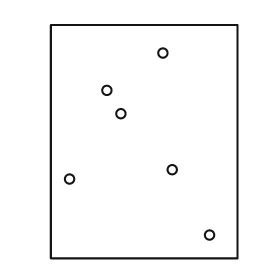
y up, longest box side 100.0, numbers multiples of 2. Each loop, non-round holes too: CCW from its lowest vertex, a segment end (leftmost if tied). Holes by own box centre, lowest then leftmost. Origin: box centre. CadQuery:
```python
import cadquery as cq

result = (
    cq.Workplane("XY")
    .moveTo(-40.0, -50.0)
    .lineTo(40.0, -50.0)
    .lineTo(40.0, 50.0)
    .lineTo(-40.0, 50.0)
    .close()
    .moveTo(28.0, -40.0)
    .circle(2.0)
    .moveTo(-32.0, -16.0)
    .circle(2.0)
    .moveTo(12.0, -12.0)
    .circle(2.0)
    .moveTo(-10.0, 12.0)
    .circle(2.0)
    .moveTo(-16.0, 22.0)
    .circle(2.0)
    .moveTo(8.0, 38.0)
    .circle(2.0)
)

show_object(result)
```